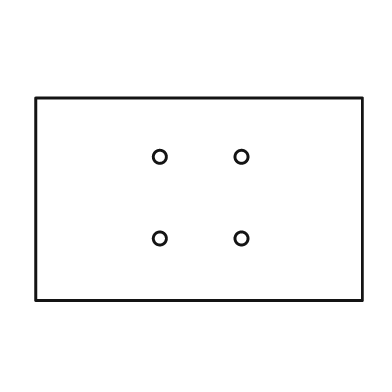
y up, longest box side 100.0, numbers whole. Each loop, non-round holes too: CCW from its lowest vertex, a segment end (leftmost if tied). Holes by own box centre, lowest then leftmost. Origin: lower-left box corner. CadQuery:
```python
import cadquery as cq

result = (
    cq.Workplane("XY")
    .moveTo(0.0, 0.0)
    .lineTo(100.0, 0.0)
    .lineTo(100.0, 62.0)
    .lineTo(0.0, 62.0)
    .close()
    .moveTo(38.0, 19.0)
    .circle(2.0)
    .moveTo(63.0, 19.0)
    .circle(2.0)
    .moveTo(38.0, 44.0)
    .circle(2.0)
    .moveTo(63.0, 44.0)
    .circle(2.0)
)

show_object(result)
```